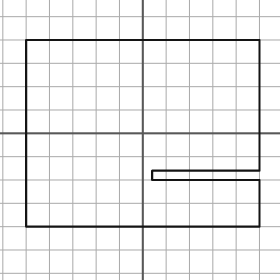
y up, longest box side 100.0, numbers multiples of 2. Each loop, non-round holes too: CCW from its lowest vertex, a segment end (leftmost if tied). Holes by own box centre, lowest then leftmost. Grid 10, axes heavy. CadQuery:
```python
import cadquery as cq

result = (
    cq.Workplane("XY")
    .moveTo(-50.0, -40.0)
    .lineTo(50.0, -40.0)
    .lineTo(50.0, -20.0)
    .lineTo(4.0, -20.0)
    .lineTo(4.0, -16.0)
    .lineTo(50.0, -16.0)
    .lineTo(50.0, 40.0)
    .lineTo(-50.0, 40.0)
    .close()
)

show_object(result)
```